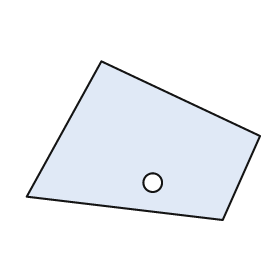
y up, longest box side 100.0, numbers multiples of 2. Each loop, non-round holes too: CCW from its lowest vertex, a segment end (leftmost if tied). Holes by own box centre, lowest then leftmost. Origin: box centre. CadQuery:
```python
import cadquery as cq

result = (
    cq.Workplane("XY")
    .moveTo(34.0, -34.0)
    .lineTo(50.0, 2.0)
    .lineTo(-18.0, 34.0)
    .lineTo(-50.0, -24.0)
    .close()
    .moveTo(4.0, -18.0)
    .circle(4.0)
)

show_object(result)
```